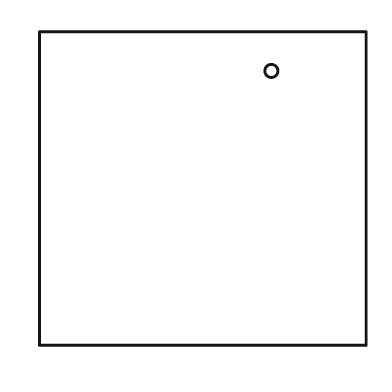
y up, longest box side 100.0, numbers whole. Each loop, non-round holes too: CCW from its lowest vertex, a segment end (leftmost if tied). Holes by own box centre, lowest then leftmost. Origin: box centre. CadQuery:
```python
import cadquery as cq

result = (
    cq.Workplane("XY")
    .moveTo(-50.0, -48.0)
    .lineTo(50.0, -48.0)
    .lineTo(50.0, 48.0)
    .lineTo(-50.0, 48.0)
    .close()
    .moveTo(21.0, 36.0)
    .circle(2.0)
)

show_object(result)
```